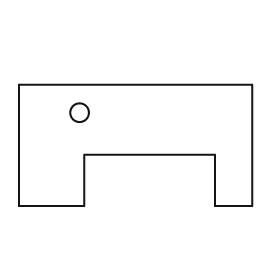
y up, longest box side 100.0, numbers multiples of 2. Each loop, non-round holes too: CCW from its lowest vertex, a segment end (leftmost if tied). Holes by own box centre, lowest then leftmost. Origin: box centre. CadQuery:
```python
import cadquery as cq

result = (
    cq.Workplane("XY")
    .moveTo(-50.0, -26.0)
    .lineTo(-22.0, -26.0)
    .lineTo(-22.0, -4.0)
    .lineTo(34.0, -4.0)
    .lineTo(34.0, -26.0)
    .lineTo(50.0, -26.0)
    .lineTo(50.0, 26.0)
    .lineTo(-50.0, 26.0)
    .close()
    .moveTo(-24.0, 14.0)
    .circle(4.0)
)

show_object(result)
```